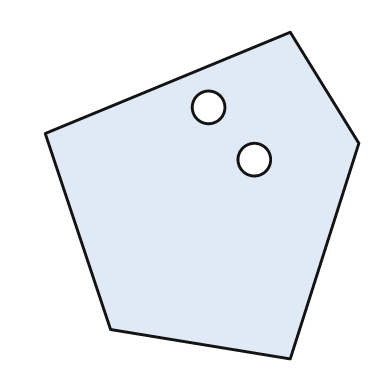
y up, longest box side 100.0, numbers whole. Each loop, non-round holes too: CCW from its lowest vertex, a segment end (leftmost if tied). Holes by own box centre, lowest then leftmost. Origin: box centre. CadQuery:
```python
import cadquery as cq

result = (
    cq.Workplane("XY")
    .moveTo(27.0, -50.0)
    .lineTo(48.0, 16.0)
    .lineTo(27.0, 50.0)
    .lineTo(-48.0, 19.0)
    .lineTo(-28.0, -41.0)
    .close()
    .moveTo(16.0, 11.0)
    .circle(5.0)
    .moveTo(2.0, 27.0)
    .circle(5.0)
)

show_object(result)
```